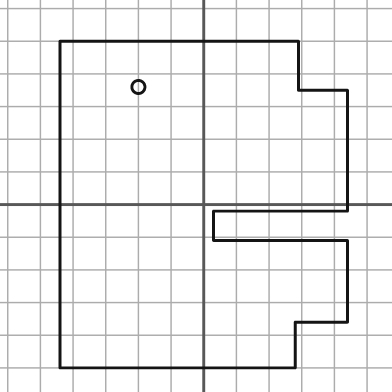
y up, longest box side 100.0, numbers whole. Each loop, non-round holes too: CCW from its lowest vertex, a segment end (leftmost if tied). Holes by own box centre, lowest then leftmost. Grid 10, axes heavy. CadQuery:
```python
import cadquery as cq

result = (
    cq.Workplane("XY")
    .moveTo(-44.0, -50.0)
    .lineTo(28.0, -50.0)
    .lineTo(28.0, -36.0)
    .lineTo(44.0, -36.0)
    .lineTo(44.0, -11.0)
    .lineTo(3.0, -11.0)
    .lineTo(3.0, -2.0)
    .lineTo(44.0, -2.0)
    .lineTo(44.0, 35.0)
    .lineTo(29.0, 35.0)
    .lineTo(29.0, 50.0)
    .lineTo(-44.0, 50.0)
    .close()
    .moveTo(-20.0, 36.0)
    .circle(2.0)
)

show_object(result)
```